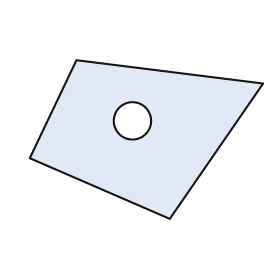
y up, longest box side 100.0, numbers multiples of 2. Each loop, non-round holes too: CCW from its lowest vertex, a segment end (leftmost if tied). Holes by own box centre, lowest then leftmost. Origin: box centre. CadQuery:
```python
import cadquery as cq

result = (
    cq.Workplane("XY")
    .moveTo(10.0, -34.0)
    .lineTo(50.0, 24.0)
    .lineTo(-30.0, 34.0)
    .lineTo(-50.0, -8.0)
    .close()
    .moveTo(-6.0, 8.0)
    .circle(8.0)
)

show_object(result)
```